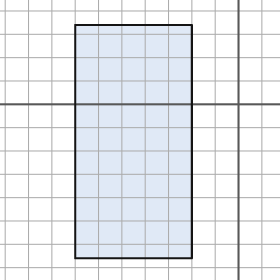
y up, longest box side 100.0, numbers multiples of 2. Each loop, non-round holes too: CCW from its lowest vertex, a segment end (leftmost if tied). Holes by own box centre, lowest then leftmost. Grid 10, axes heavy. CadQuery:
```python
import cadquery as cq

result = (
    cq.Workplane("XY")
    .moveTo(-70.0, -66.0)
    .lineTo(-20.0, -66.0)
    .lineTo(-20.0, 34.0)
    .lineTo(-70.0, 34.0)
    .close()
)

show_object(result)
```